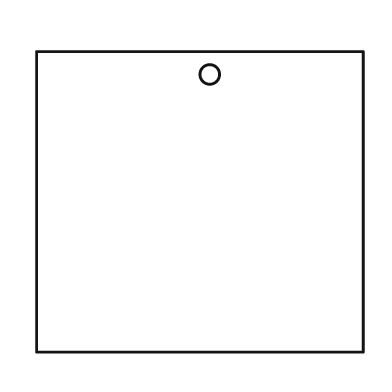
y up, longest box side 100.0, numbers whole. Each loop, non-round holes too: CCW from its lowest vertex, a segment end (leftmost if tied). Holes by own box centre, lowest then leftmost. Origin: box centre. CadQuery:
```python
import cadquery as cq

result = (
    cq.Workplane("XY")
    .moveTo(-50.0, -46.0)
    .lineTo(50.0, -46.0)
    .lineTo(50.0, 46.0)
    .lineTo(-50.0, 46.0)
    .close()
    .moveTo(3.0, 39.0)
    .circle(3.0)
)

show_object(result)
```